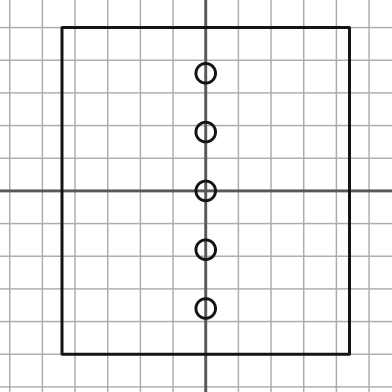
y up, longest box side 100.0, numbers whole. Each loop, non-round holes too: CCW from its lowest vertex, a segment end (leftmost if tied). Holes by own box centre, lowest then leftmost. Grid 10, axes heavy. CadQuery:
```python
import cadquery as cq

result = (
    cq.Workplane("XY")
    .moveTo(-44.0, -50.0)
    .lineTo(44.0, -50.0)
    .lineTo(44.0, 50.0)
    .lineTo(-44.0, 50.0)
    .close()
    .moveTo(0.0, -36.0)
    .circle(3.0)
    .moveTo(0.0, -18.0)
    .circle(3.0)
    .moveTo(0.0, 0.0)
    .circle(3.0)
    .moveTo(0.0, 18.0)
    .circle(3.0)
    .moveTo(0.0, 36.0)
    .circle(3.0)
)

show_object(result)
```